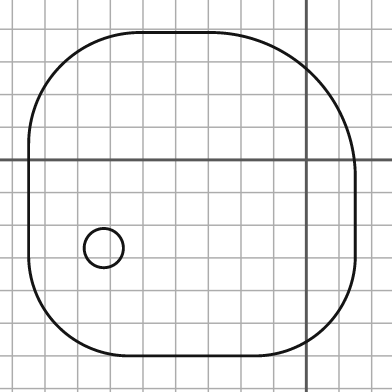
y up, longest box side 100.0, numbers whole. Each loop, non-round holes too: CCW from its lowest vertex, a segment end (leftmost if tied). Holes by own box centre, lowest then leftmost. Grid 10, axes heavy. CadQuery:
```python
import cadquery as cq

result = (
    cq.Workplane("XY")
    .moveTo(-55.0, -60.0)
    .lineTo(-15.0, -60.0)
    .threePointArc((6.0, -51.0), (15.0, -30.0))
    .lineTo(15.0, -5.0)
    .threePointArc((2.0, 26.0), (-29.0, 39.0))
    .lineTo(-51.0, 39.0)
    .threePointArc((-75.0, 29.0), (-85.0, 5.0))
    .lineTo(-85.0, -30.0)
    .threePointArc((-76.0, -51.0), (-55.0, -60.0))
    .close()
    .moveTo(-62.0, -27.0)
    .circle(6.0)
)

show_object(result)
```